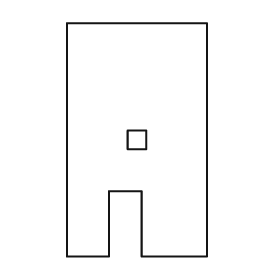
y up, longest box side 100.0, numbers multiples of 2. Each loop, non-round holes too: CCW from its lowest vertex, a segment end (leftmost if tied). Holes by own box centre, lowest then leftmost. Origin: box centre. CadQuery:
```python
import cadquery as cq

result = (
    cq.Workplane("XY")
    .moveTo(-30.0, -50.0)
    .lineTo(-12.0, -50.0)
    .lineTo(-12.0, -22.0)
    .lineTo(2.0, -22.0)
    .lineTo(2.0, -50.0)
    .lineTo(30.0, -50.0)
    .lineTo(30.0, 50.0)
    .lineTo(-30.0, 50.0)
    .close()
    .moveTo(-4.0, -4.0)
    .lineTo(4.0, -4.0)
    .lineTo(4.0, 4.0)
    .lineTo(-4.0, 4.0)
    .close()
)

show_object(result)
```